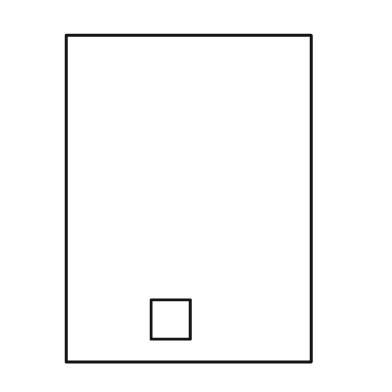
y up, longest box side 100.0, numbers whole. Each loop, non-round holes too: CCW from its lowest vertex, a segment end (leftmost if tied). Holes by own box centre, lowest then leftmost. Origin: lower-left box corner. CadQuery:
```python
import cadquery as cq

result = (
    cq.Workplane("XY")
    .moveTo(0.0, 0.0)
    .lineTo(75.0, 0.0)
    .lineTo(75.0, 100.0)
    .lineTo(0.0, 100.0)
    .close()
    .moveTo(26.0, 7.0)
    .lineTo(38.0, 7.0)
    .lineTo(38.0, 19.0)
    .lineTo(26.0, 19.0)
    .close()
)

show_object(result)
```